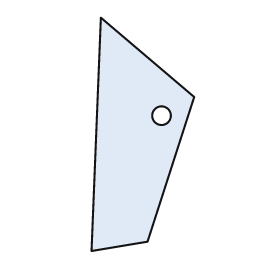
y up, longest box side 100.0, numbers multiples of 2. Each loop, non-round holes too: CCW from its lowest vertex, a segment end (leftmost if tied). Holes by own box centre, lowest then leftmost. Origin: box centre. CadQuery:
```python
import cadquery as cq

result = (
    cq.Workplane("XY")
    .moveTo(-22.0, -50.0)
    .lineTo(2.0, -46.0)
    .lineTo(22.0, 16.0)
    .lineTo(-18.0, 50.0)
    .close()
    .moveTo(8.0, 8.0)
    .circle(4.0)
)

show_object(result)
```